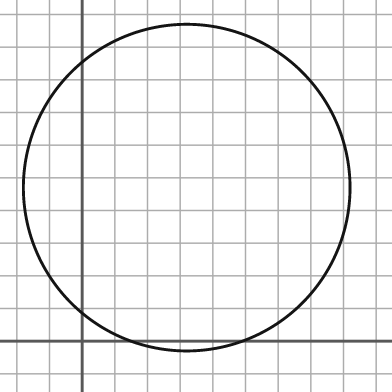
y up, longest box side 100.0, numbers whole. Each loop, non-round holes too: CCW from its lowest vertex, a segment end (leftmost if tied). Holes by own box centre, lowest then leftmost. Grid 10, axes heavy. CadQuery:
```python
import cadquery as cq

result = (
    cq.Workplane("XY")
    .moveTo(32.0, 47.0)
    .circle(50.0)
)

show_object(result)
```